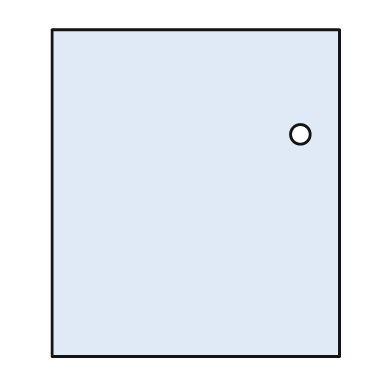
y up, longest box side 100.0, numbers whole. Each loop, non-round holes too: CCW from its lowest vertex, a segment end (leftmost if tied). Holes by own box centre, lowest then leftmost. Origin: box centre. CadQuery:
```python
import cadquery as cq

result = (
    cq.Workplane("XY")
    .moveTo(-44.0, -50.0)
    .lineTo(44.0, -50.0)
    .lineTo(44.0, 50.0)
    .lineTo(-44.0, 50.0)
    .close()
    .moveTo(32.0, 18.0)
    .circle(3.0)
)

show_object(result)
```